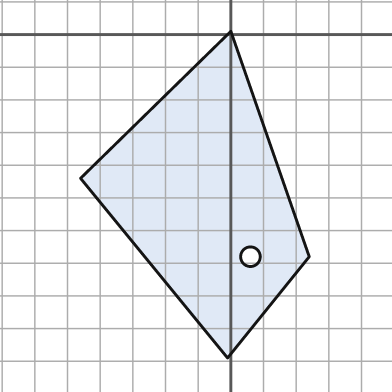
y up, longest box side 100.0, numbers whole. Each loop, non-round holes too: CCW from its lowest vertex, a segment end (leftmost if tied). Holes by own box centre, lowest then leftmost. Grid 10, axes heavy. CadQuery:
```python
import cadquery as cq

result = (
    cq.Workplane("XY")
    .moveTo(-1.0, -99.0)
    .lineTo(24.0, -68.0)
    .lineTo(0.0, 1.0)
    .lineTo(-46.0, -44.0)
    .close()
    .moveTo(6.0, -68.0)
    .circle(3.0)
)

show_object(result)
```